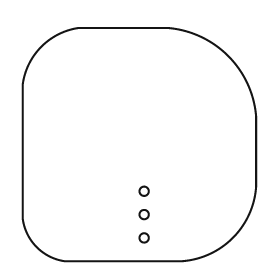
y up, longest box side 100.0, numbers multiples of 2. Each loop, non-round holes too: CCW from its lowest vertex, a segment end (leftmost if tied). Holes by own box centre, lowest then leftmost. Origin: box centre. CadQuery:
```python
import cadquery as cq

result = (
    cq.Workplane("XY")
    .moveTo(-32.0, -50.0)
    .lineTo(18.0, -50.0)
    .threePointArc((40.0, -40.0), (50.0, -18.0))
    .lineTo(50.0, 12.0)
    .threePointArc((38.0, 38.0), (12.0, 50.0))
    .lineTo(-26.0, 50.0)
    .threePointArc((-42.0, 42.0), (-50.0, 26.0))
    .lineTo(-50.0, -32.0)
    .threePointArc((-44.0, -44.0), (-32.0, -50.0))
    .close()
    .moveTo(2.0, -40.0)
    .circle(2.0)
    .moveTo(2.0, -30.0)
    .circle(2.0)
    .moveTo(2.0, -20.0)
    .circle(2.0)
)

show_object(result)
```